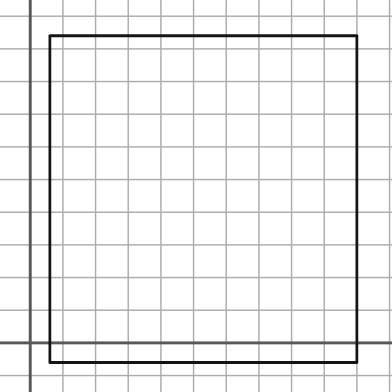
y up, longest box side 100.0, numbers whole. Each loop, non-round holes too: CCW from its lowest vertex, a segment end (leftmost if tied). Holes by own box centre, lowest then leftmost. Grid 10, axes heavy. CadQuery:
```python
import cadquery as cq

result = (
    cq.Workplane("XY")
    .moveTo(6.0, -6.0)
    .lineTo(100.0, -6.0)
    .lineTo(100.0, 94.0)
    .lineTo(6.0, 94.0)
    .close()
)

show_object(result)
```